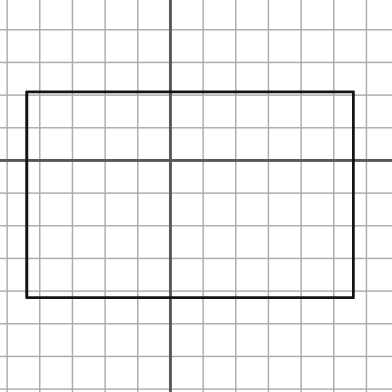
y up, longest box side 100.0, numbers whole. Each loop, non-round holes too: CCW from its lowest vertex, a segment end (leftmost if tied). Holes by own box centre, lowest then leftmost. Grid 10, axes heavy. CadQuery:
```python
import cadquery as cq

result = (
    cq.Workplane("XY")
    .moveTo(-44.0, -42.0)
    .lineTo(56.0, -42.0)
    .lineTo(56.0, 21.0)
    .lineTo(-44.0, 21.0)
    .close()
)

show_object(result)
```